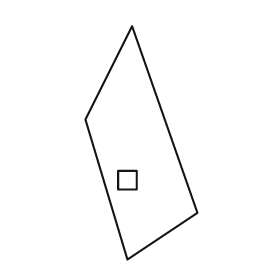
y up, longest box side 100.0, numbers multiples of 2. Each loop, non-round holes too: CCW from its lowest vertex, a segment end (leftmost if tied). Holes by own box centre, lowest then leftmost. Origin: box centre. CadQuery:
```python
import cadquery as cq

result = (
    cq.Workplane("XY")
    .moveTo(-6.0, -50.0)
    .lineTo(24.0, -30.0)
    .lineTo(-4.0, 50.0)
    .lineTo(-24.0, 10.0)
    .close()
    .moveTo(-10.0, -20.0)
    .lineTo(-2.0, -20.0)
    .lineTo(-2.0, -12.0)
    .lineTo(-10.0, -12.0)
    .close()
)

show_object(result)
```